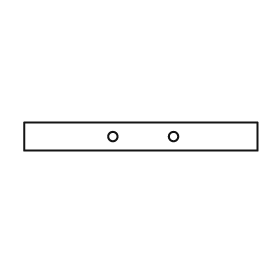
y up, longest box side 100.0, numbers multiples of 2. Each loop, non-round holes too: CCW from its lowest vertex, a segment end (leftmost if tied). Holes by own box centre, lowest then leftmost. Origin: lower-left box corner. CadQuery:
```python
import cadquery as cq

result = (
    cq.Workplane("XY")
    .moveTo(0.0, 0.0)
    .lineTo(100.0, 0.0)
    .lineTo(100.0, 12.0)
    .lineTo(0.0, 12.0)
    .close()
    .moveTo(38.0, 6.0)
    .circle(2.0)
    .moveTo(64.0, 6.0)
    .circle(2.0)
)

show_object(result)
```